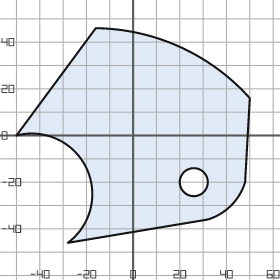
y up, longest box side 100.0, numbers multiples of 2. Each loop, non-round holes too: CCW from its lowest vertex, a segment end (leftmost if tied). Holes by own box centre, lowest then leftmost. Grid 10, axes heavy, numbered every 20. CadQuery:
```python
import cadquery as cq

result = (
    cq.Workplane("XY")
    .moveTo(-28.0, -46.0)
    .lineTo(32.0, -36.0)
    .threePointArc((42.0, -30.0), (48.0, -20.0))
    .lineTo(50.0, 16.0)
    .threePointArc((20.0, 38.0), (-16.0, 46.0))
    .lineTo(-50.0, 0.0)
    .threePointArc((-20.0, -14.0), (-28.0, -46.0))
    .close()
    .moveTo(26.0, -20.0)
    .circle(6.0)
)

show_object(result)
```